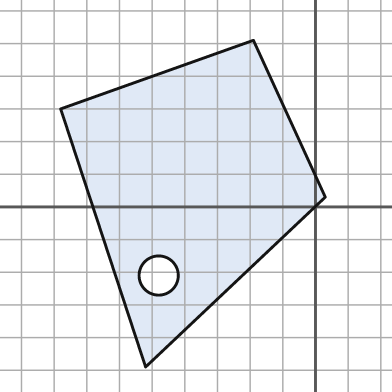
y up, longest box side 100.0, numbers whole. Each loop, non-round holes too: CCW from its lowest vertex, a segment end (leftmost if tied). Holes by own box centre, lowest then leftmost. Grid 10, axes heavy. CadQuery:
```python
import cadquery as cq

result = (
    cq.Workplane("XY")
    .moveTo(-52.0, -49.0)
    .lineTo(3.0, 3.0)
    .lineTo(-19.0, 51.0)
    .lineTo(-78.0, 30.0)
    .close()
    .moveTo(-48.0, -21.0)
    .circle(6.0)
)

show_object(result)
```